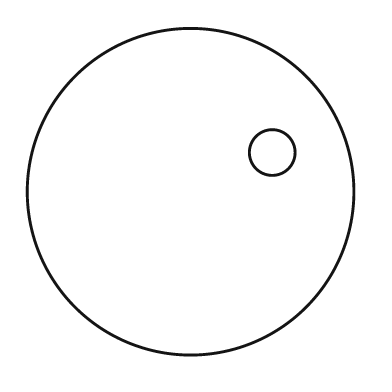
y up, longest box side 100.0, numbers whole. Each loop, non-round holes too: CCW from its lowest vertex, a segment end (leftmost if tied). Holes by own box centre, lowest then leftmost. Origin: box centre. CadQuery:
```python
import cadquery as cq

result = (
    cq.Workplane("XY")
    .moveTo(0.0, 0.0)
    .circle(50.0)
    .moveTo(25.0, 12.0)
    .circle(7.0)
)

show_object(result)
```